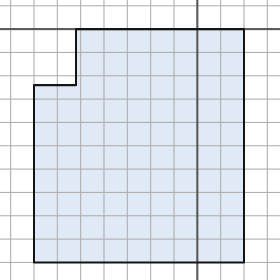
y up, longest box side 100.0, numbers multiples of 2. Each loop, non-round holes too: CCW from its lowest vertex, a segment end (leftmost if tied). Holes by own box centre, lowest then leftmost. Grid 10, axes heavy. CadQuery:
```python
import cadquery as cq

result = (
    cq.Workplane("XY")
    .moveTo(-70.0, -100.0)
    .lineTo(20.0, -100.0)
    .lineTo(20.0, 0.0)
    .lineTo(-52.0, 0.0)
    .lineTo(-52.0, -24.0)
    .lineTo(-70.0, -24.0)
    .close()
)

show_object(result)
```